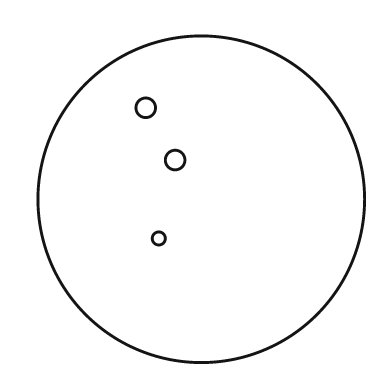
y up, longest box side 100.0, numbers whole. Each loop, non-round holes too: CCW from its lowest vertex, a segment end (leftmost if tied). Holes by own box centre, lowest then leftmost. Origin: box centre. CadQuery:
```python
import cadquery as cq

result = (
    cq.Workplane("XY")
    .moveTo(0.0, 0.0)
    .circle(50.0)
    .moveTo(-13.0, -12.0)
    .circle(2.0)
    .moveTo(-8.0, 12.0)
    .circle(3.0)
    .moveTo(-17.0, 28.0)
    .circle(3.0)
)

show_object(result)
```